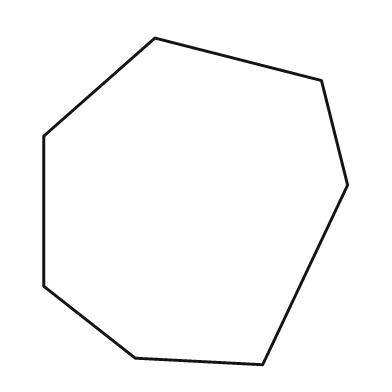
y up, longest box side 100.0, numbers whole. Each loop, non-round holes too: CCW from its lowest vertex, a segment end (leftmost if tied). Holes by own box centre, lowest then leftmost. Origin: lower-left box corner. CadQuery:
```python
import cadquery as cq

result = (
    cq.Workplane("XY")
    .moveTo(67.0, 0.0)
    .lineTo(93.0, 55.0)
    .lineTo(85.0, 87.0)
    .lineTo(34.0, 100.0)
    .lineTo(0.0, 70.0)
    .lineTo(0.0, 24.0)
    .lineTo(28.0, 2.0)
    .close()
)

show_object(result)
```